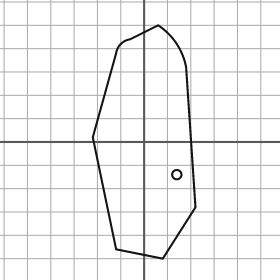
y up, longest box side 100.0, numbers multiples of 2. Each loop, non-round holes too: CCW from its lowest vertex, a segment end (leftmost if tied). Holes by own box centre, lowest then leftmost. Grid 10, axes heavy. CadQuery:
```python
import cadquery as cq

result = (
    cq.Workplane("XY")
    .moveTo(8.0, -50.0)
    .lineTo(22.0, -28.0)
    .lineTo(18.0, 32.0)
    .threePointArc((14.0, 42.0), (6.0, 50.0))
    .lineTo(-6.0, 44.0)
    .threePointArc((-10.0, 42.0), (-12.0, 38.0))
    .lineTo(-22.0, 2.0)
    .lineTo(-12.0, -46.0)
    .close()
    .moveTo(14.0, -14.0)
    .circle(2.0)
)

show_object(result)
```